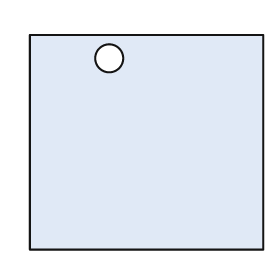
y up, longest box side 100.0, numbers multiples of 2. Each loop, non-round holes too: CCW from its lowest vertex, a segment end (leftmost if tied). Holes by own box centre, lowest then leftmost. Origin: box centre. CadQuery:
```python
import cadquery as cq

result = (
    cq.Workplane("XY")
    .moveTo(-50.0, -46.0)
    .lineTo(50.0, -46.0)
    .lineTo(50.0, 46.0)
    .lineTo(-50.0, 46.0)
    .close()
    .moveTo(-16.0, 36.0)
    .circle(6.0)
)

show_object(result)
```